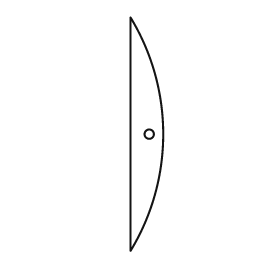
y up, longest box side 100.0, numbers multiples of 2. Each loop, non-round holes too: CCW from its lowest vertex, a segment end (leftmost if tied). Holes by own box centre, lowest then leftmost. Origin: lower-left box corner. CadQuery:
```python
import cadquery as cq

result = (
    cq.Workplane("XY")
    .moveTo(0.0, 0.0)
    .threePointArc((14.0, 50.0), (0.0, 100.0))
    .close()
    .moveTo(8.0, 50.0)
    .circle(2.0)
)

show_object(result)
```